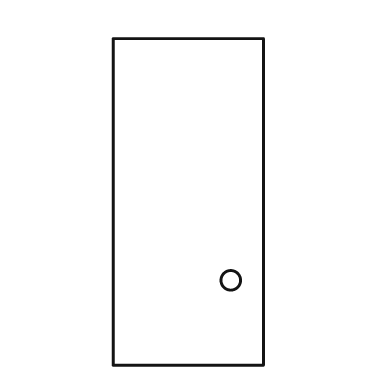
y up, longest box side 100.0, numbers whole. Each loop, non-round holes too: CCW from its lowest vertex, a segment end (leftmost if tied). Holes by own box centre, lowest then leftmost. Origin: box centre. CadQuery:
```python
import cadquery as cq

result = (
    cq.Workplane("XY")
    .moveTo(-23.0, -50.0)
    .lineTo(23.0, -50.0)
    .lineTo(23.0, 50.0)
    .lineTo(-23.0, 50.0)
    .close()
    .moveTo(13.0, -24.0)
    .circle(3.0)
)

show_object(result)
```